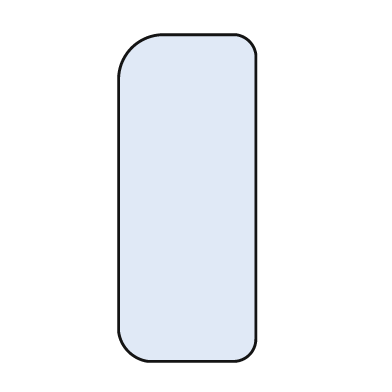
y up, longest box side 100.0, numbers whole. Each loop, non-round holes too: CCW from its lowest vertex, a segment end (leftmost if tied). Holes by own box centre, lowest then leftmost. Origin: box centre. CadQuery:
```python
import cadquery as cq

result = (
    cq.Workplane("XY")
    .moveTo(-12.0, -50.0)
    .lineTo(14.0, -50.0)
    .threePointArc((19.0, -48.0), (21.0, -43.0))
    .lineTo(21.0, 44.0)
    .threePointArc((19.0, 48.0), (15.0, 50.0))
    .lineTo(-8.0, 50.0)
    .threePointArc((-17.0, 46.0), (-21.0, 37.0))
    .lineTo(-21.0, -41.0)
    .threePointArc((-18.0, -47.0), (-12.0, -50.0))
    .close()
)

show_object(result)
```